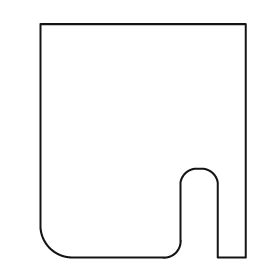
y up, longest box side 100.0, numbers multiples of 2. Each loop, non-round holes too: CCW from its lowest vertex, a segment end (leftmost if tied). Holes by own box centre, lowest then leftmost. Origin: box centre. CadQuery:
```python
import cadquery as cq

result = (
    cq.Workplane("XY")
    .moveTo(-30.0, -50.0)
    .lineTo(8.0, -50.0)
    .threePointArc((14.0, -48.0), (16.0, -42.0))
    .lineTo(16.0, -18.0)
    .threePointArc((18.0, -14.0), (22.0, -12.0))
    .lineTo(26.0, -12.0)
    .threePointArc((30.0, -14.0), (32.0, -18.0))
    .lineTo(32.0, -50.0)
    .lineTo(44.0, -50.0)
    .lineTo(44.0, 50.0)
    .lineTo(-44.0, 50.0)
    .lineTo(-44.0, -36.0)
    .threePointArc((-40.0, -46.0), (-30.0, -50.0))
    .close()
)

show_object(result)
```